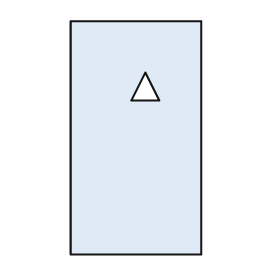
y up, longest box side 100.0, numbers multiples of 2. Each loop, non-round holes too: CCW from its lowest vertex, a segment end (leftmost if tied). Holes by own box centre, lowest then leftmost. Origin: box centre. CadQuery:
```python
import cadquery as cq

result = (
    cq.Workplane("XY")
    .moveTo(-28.0, -50.0)
    .lineTo(28.0, -50.0)
    .lineTo(28.0, 50.0)
    .lineTo(-28.0, 50.0)
    .close()
    .moveTo(-2.0, 16.0)
    .lineTo(10.0, 16.0)
    .lineTo(4.0, 28.0)
    .close()
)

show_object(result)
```